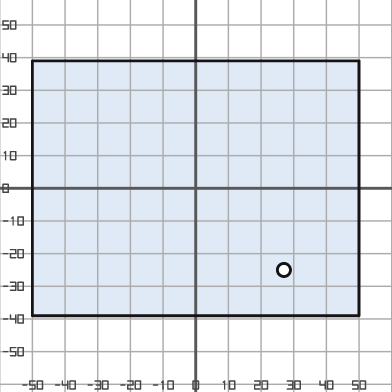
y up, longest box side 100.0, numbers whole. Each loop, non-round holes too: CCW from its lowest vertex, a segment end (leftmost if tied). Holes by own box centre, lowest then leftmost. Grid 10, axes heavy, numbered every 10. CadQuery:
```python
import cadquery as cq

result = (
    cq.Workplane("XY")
    .moveTo(-50.0, -39.0)
    .lineTo(50.0, -39.0)
    .lineTo(50.0, 39.0)
    .lineTo(-50.0, 39.0)
    .close()
    .moveTo(27.0, -25.0)
    .circle(2.0)
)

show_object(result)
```